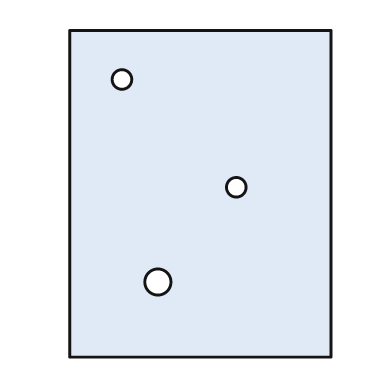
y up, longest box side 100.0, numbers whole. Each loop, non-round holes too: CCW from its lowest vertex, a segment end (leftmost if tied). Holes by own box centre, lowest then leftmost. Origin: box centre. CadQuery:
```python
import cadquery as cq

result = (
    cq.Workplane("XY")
    .moveTo(-40.0, -50.0)
    .lineTo(40.0, -50.0)
    .lineTo(40.0, 50.0)
    .lineTo(-40.0, 50.0)
    .close()
    .moveTo(-13.0, -27.0)
    .circle(4.0)
    .moveTo(11.0, 2.0)
    .circle(3.0)
    .moveTo(-24.0, 35.0)
    .circle(3.0)
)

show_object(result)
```